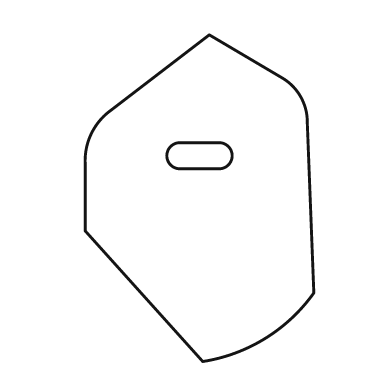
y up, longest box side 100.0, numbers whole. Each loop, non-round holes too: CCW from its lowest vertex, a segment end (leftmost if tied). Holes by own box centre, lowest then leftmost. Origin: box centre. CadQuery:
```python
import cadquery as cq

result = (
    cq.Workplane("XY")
    .moveTo(1.0, -50.0)
    .threePointArc((20.0, -43.0), (35.0, -29.0))
    .lineTo(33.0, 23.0)
    .threePointArc((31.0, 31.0), (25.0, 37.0))
    .lineTo(3.0, 50.0)
    .lineTo(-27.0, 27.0)
    .threePointArc((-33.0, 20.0), (-35.0, 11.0))
    .lineTo(-35.0, -10.0)
    .close()
    .moveTo(-6.0, 9.0)
    .lineTo(6.0, 9.0)
    .threePointArc((10.0, 13.0), (6.0, 17.0))
    .lineTo(-6.0, 17.0)
    .threePointArc((-10.0, 13.0), (-6.0, 9.0))
    .close()
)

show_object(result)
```